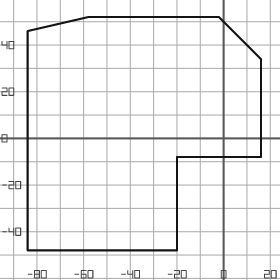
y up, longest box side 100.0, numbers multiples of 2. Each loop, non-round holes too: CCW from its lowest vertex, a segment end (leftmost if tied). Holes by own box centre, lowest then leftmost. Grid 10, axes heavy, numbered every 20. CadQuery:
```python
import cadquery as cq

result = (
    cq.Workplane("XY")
    .moveTo(-84.0, -48.0)
    .lineTo(-20.0, -48.0)
    .lineTo(-20.0, -8.0)
    .lineTo(16.0, -8.0)
    .lineTo(16.0, 34.0)
    .lineTo(-2.0, 52.0)
    .lineTo(-58.0, 52.0)
    .lineTo(-84.0, 46.0)
    .close()
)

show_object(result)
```